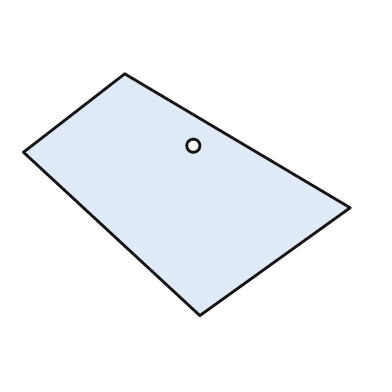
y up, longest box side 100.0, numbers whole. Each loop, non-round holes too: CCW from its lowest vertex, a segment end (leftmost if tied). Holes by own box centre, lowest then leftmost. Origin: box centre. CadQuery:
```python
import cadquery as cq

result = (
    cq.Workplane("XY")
    .moveTo(4.0, -37.0)
    .lineTo(50.0, -4.0)
    .lineTo(-19.0, 37.0)
    .lineTo(-50.0, 13.0)
    .close()
    .moveTo(2.0, 15.0)
    .circle(2.0)
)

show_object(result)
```